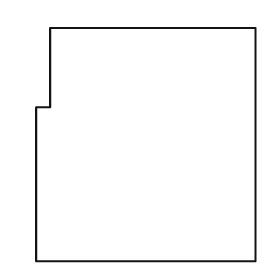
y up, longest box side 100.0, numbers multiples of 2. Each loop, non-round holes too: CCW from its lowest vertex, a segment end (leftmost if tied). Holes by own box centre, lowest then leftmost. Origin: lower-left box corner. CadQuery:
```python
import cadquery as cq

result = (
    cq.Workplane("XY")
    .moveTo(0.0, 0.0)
    .lineTo(94.0, 0.0)
    .lineTo(94.0, 100.0)
    .lineTo(6.0, 100.0)
    .lineTo(6.0, 66.0)
    .lineTo(0.0, 66.0)
    .close()
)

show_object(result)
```